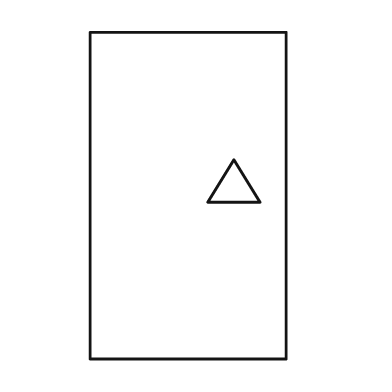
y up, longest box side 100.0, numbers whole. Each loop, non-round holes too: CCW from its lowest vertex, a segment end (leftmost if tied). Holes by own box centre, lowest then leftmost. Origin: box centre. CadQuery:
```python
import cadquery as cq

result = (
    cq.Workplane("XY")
    .moveTo(-30.0, -50.0)
    .lineTo(30.0, -50.0)
    .lineTo(30.0, 50.0)
    .lineTo(-30.0, 50.0)
    .close()
    .moveTo(6.0, -2.0)
    .lineTo(22.0, -2.0)
    .lineTo(14.0, 11.0)
    .close()
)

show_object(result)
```